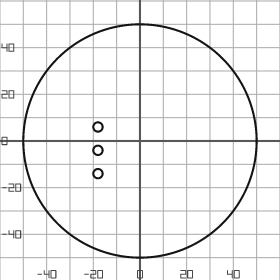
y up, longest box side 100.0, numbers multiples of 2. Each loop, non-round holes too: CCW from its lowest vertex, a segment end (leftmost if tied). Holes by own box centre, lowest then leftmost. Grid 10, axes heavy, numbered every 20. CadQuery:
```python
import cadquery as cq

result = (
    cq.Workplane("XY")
    .moveTo(0.0, 0.0)
    .circle(50.0)
    .moveTo(-18.0, -14.0)
    .circle(2.0)
    .moveTo(-18.0, -4.0)
    .circle(2.0)
    .moveTo(-18.0, 6.0)
    .circle(2.0)
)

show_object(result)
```